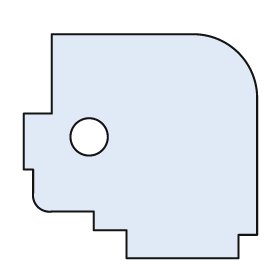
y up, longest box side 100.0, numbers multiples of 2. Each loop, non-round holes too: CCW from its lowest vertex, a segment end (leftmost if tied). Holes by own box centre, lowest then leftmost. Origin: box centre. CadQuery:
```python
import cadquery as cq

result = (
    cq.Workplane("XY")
    .moveTo(-6.0, -48.0)
    .lineTo(42.0, -48.0)
    .lineTo(42.0, -38.0)
    .lineTo(50.0, -38.0)
    .lineTo(50.0, 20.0)
    .threePointArc((42.0, 40.0), (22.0, 48.0))
    .lineTo(-38.0, 48.0)
    .lineTo(-38.0, 14.0)
    .lineTo(-50.0, 14.0)
    .lineTo(-50.0, -10.0)
    .lineTo(-46.0, -10.0)
    .lineTo(-46.0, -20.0)
    .threePointArc((-44.0, -26.0), (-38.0, -28.0))
    .lineTo(-20.0, -28.0)
    .lineTo(-20.0, -36.0)
    .lineTo(-6.0, -36.0)
    .close()
    .moveTo(-22.0, 4.0)
    .circle(8.0)
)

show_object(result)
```